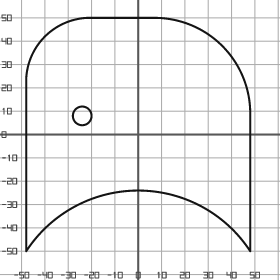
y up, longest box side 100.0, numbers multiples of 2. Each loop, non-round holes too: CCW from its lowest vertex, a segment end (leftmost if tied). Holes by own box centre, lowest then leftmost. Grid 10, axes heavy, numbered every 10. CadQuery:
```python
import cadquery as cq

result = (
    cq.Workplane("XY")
    .moveTo(-48.0, -50.0)
    .threePointArc((0.0, -24.0), (48.0, -50.0))
    .lineTo(48.0, 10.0)
    .threePointArc((36.0, 38.0), (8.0, 50.0))
    .lineTo(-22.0, 50.0)
    .threePointArc((-40.0, 42.0), (-48.0, 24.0))
    .close()
    .moveTo(-24.0, 8.0)
    .circle(4.0)
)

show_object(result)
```